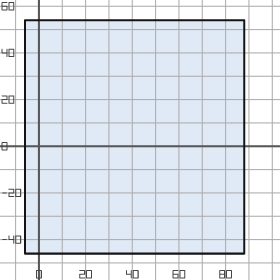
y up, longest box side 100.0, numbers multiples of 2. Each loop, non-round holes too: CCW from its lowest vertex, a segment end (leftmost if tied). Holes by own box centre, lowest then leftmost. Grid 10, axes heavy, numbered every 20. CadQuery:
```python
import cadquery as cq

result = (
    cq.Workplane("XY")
    .moveTo(-6.0, -46.0)
    .lineTo(88.0, -46.0)
    .lineTo(88.0, 54.0)
    .lineTo(-6.0, 54.0)
    .close()
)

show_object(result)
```